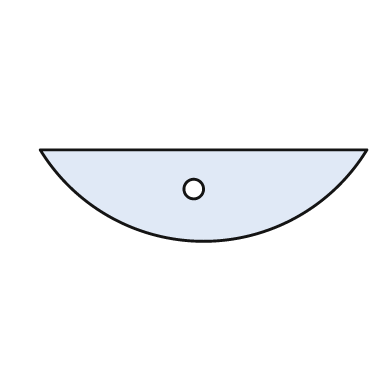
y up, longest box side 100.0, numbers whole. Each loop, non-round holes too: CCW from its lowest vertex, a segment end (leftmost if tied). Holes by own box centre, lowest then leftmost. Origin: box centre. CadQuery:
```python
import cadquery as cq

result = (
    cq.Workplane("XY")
    .moveTo(-50.0, 14.0)
    .threePointArc((0.0, -14.0), (50.0, 14.0))
    .close()
    .moveTo(-3.0, 2.0)
    .circle(3.0)
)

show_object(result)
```